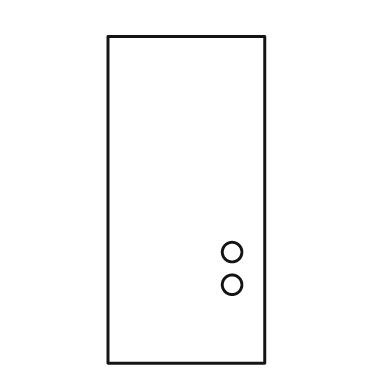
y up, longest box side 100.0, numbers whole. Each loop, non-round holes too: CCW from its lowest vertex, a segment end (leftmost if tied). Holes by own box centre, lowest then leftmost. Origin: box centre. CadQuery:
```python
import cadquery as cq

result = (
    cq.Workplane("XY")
    .moveTo(-24.0, -50.0)
    .lineTo(24.0, -50.0)
    .lineTo(24.0, 50.0)
    .lineTo(-24.0, 50.0)
    .close()
    .moveTo(14.0, -26.0)
    .circle(3.0)
    .moveTo(14.0, -16.0)
    .circle(3.0)
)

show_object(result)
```